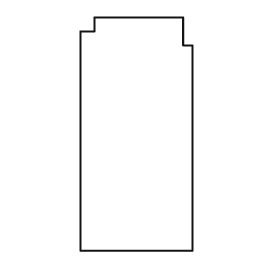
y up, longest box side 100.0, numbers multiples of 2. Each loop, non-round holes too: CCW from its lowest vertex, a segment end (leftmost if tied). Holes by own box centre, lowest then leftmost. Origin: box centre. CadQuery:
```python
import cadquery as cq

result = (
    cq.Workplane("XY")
    .moveTo(-24.0, -50.0)
    .lineTo(24.0, -50.0)
    .lineTo(24.0, 38.0)
    .lineTo(20.0, 38.0)
    .lineTo(20.0, 50.0)
    .lineTo(-18.0, 50.0)
    .lineTo(-18.0, 44.0)
    .lineTo(-24.0, 44.0)
    .close()
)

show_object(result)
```